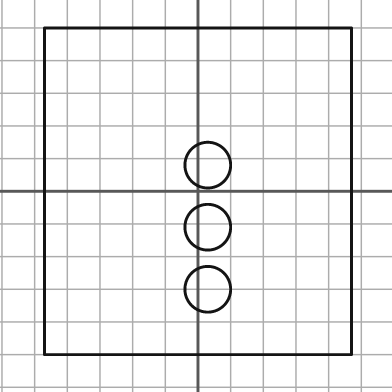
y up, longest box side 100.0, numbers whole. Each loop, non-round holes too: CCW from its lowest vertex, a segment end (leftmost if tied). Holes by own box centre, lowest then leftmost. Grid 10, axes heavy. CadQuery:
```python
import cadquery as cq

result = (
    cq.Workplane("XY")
    .moveTo(-47.0, -50.0)
    .lineTo(47.0, -50.0)
    .lineTo(47.0, 50.0)
    .lineTo(-47.0, 50.0)
    .close()
    .moveTo(3.0, -30.0)
    .circle(7.0)
    .moveTo(3.0, -11.0)
    .circle(7.0)
    .moveTo(3.0, 8.0)
    .circle(7.0)
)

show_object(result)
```